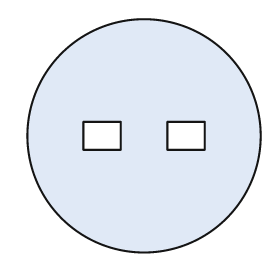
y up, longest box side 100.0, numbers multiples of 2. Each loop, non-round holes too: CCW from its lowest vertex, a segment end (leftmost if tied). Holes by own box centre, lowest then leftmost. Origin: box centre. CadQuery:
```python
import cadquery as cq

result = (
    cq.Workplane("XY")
    .moveTo(0.0, 0.0)
    .circle(50.0)
    .moveTo(-26.0, -6.0)
    .lineTo(-10.0, -6.0)
    .lineTo(-10.0, 6.0)
    .lineTo(-26.0, 6.0)
    .close()
    .moveTo(10.0, -6.0)
    .lineTo(26.0, -6.0)
    .lineTo(26.0, 6.0)
    .lineTo(10.0, 6.0)
    .close()
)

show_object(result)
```